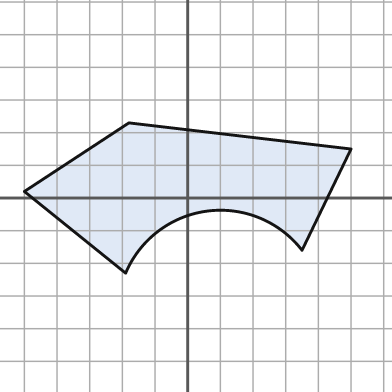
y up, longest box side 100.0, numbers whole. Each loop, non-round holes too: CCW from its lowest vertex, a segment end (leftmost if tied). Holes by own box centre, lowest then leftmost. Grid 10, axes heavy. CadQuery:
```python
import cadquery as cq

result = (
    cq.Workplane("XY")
    .moveTo(-19.0, -23.0)
    .threePointArc((6.0, -4.0), (35.0, -16.0))
    .lineTo(50.0, 15.0)
    .lineTo(-18.0, 23.0)
    .lineTo(-50.0, 2.0)
    .close()
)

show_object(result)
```